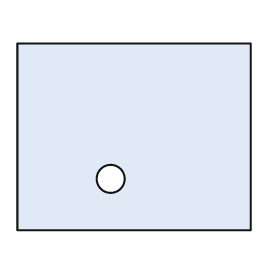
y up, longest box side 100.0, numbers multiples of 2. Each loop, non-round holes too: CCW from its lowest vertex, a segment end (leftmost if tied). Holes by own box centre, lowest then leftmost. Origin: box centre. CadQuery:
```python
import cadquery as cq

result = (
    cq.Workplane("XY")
    .moveTo(-50.0, -40.0)
    .lineTo(50.0, -40.0)
    .lineTo(50.0, 40.0)
    .lineTo(-50.0, 40.0)
    .close()
    .moveTo(-10.0, -18.0)
    .circle(6.0)
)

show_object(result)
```